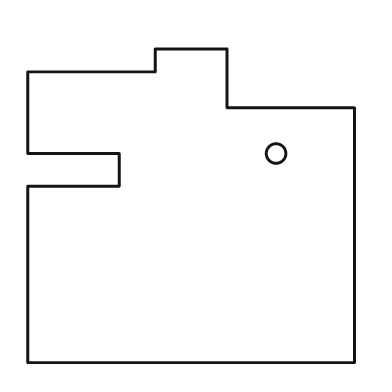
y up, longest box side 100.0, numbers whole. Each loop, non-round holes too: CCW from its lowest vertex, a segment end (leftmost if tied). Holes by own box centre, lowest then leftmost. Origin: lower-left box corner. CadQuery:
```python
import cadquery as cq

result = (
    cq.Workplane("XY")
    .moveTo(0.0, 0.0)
    .lineTo(100.0, 0.0)
    .lineTo(100.0, 78.0)
    .lineTo(61.0, 78.0)
    .lineTo(61.0, 96.0)
    .lineTo(39.0, 96.0)
    .lineTo(39.0, 89.0)
    .lineTo(0.0, 89.0)
    .lineTo(0.0, 64.0)
    .lineTo(28.0, 64.0)
    .lineTo(28.0, 54.0)
    .lineTo(0.0, 54.0)
    .close()
    .moveTo(76.0, 64.0)
    .circle(3.0)
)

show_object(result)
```